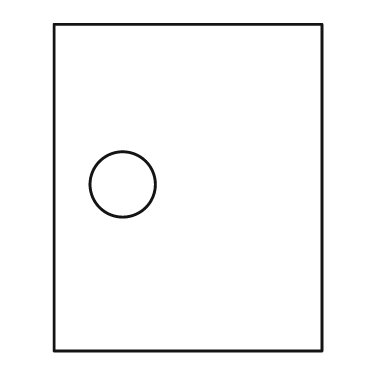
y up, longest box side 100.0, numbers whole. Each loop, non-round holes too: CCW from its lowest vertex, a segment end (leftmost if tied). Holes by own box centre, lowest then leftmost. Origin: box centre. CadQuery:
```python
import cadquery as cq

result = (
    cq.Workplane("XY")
    .moveTo(-41.0, -50.0)
    .lineTo(41.0, -50.0)
    .lineTo(41.0, 50.0)
    .lineTo(-41.0, 50.0)
    .close()
    .moveTo(-20.0, 1.0)
    .circle(10.0)
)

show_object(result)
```